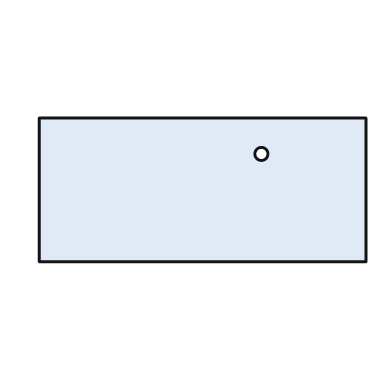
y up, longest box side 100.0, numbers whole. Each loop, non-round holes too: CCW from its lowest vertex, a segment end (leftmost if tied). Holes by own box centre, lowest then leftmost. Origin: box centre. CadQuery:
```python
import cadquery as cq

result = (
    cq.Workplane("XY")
    .moveTo(-50.0, -22.0)
    .lineTo(50.0, -22.0)
    .lineTo(50.0, 22.0)
    .lineTo(-50.0, 22.0)
    .close()
    .moveTo(18.0, 11.0)
    .circle(2.0)
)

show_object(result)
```